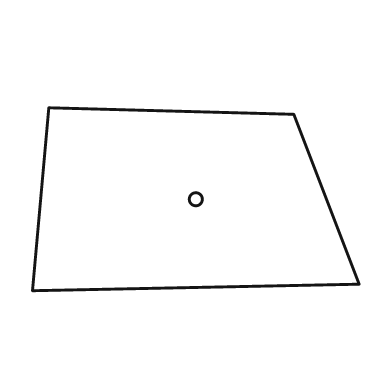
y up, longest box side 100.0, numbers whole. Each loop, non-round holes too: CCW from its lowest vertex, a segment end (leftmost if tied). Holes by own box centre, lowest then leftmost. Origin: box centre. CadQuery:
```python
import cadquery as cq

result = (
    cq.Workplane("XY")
    .moveTo(-50.0, -28.0)
    .lineTo(50.0, -26.0)
    .lineTo(30.0, 26.0)
    .lineTo(-45.0, 28.0)
    .close()
    .moveTo(0.0, 0.0)
    .circle(2.0)
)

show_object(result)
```